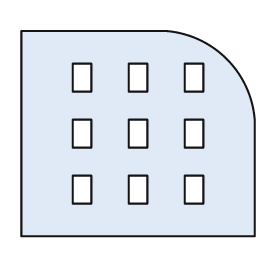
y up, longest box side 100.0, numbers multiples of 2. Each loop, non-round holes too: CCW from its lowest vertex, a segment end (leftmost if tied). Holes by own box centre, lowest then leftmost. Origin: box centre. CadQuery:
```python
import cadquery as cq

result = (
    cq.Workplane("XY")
    .moveTo(-50.0, -44.0)
    .lineTo(50.0, -44.0)
    .lineTo(50.0, 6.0)
    .threePointArc((38.0, 32.0), (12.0, 44.0))
    .lineTo(-50.0, 44.0)
    .close()
    .moveTo(-28.0, -30.0)
    .lineTo(-20.0, -30.0)
    .lineTo(-20.0, -18.0)
    .lineTo(-28.0, -18.0)
    .close()
    .moveTo(-4.0, -30.0)
    .lineTo(4.0, -30.0)
    .lineTo(4.0, -18.0)
    .lineTo(-4.0, -18.0)
    .close()
    .moveTo(20.0, -30.0)
    .lineTo(28.0, -30.0)
    .lineTo(28.0, -18.0)
    .lineTo(20.0, -18.0)
    .close()
    .moveTo(-28.0, -6.0)
    .lineTo(-20.0, -6.0)
    .lineTo(-20.0, 6.0)
    .lineTo(-28.0, 6.0)
    .close()
    .moveTo(-4.0, -6.0)
    .lineTo(4.0, -6.0)
    .lineTo(4.0, 6.0)
    .lineTo(-4.0, 6.0)
    .close()
    .moveTo(20.0, -6.0)
    .lineTo(28.0, -6.0)
    .lineTo(28.0, 6.0)
    .lineTo(20.0, 6.0)
    .close()
    .moveTo(-28.0, 18.0)
    .lineTo(-20.0, 18.0)
    .lineTo(-20.0, 30.0)
    .lineTo(-28.0, 30.0)
    .close()
    .moveTo(-4.0, 18.0)
    .lineTo(4.0, 18.0)
    .lineTo(4.0, 30.0)
    .lineTo(-4.0, 30.0)
    .close()
    .moveTo(20.0, 18.0)
    .lineTo(28.0, 18.0)
    .lineTo(28.0, 30.0)
    .lineTo(20.0, 30.0)
    .close()
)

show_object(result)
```